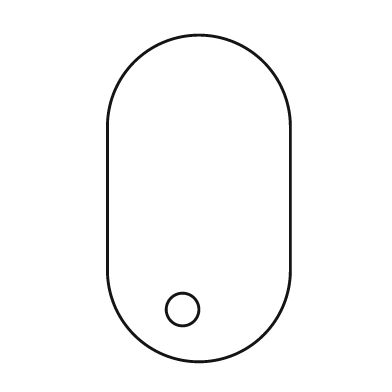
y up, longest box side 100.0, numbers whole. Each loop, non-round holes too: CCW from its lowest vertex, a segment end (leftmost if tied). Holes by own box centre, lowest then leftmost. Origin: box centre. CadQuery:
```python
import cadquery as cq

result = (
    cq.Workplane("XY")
    .moveTo(-28.0, -22.0)
    .threePointArc((0.0, -50.0), (28.0, -22.0))
    .lineTo(28.0, 22.0)
    .threePointArc((0.0, 50.0), (-28.0, 22.0))
    .close()
    .moveTo(-5.0, -34.0)
    .circle(5.0)
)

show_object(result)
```